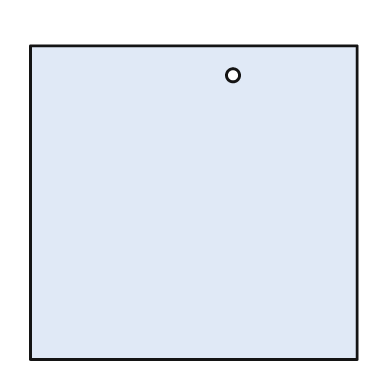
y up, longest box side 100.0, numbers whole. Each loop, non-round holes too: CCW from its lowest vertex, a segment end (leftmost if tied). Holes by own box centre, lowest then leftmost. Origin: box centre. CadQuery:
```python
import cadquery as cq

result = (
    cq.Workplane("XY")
    .moveTo(-50.0, -48.0)
    .lineTo(50.0, -48.0)
    .lineTo(50.0, 48.0)
    .lineTo(-50.0, 48.0)
    .close()
    .moveTo(12.0, 39.0)
    .circle(2.0)
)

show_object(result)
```